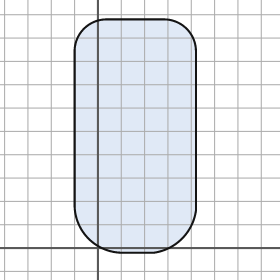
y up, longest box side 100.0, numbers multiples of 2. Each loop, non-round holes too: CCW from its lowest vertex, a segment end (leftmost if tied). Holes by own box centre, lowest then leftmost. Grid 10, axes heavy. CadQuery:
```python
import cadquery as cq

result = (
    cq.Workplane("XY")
    .moveTo(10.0, -2.0)
    .lineTo(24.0, -2.0)
    .threePointArc((36.0, 4.0), (42.0, 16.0))
    .lineTo(42.0, 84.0)
    .threePointArc((38.0, 94.0), (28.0, 98.0))
    .lineTo(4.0, 98.0)
    .threePointArc((-6.0, 94.0), (-10.0, 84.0))
    .lineTo(-10.0, 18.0)
    .threePointArc((-4.0, 4.0), (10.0, -2.0))
    .close()
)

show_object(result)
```